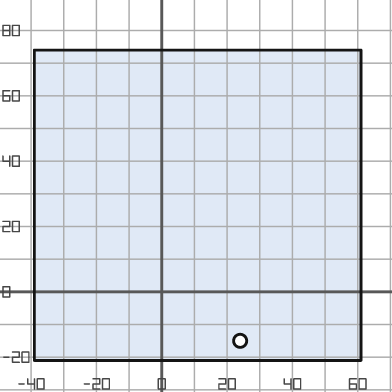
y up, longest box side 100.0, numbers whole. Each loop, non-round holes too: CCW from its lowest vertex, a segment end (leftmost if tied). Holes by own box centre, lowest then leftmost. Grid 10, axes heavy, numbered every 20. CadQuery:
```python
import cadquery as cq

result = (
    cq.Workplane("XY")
    .moveTo(-39.0, -21.0)
    .lineTo(61.0, -21.0)
    .lineTo(61.0, 74.0)
    .lineTo(-39.0, 74.0)
    .close()
    .moveTo(24.0, -15.0)
    .circle(2.0)
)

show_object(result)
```